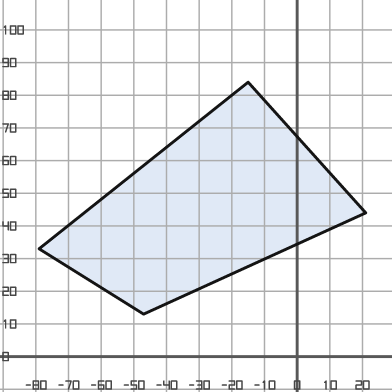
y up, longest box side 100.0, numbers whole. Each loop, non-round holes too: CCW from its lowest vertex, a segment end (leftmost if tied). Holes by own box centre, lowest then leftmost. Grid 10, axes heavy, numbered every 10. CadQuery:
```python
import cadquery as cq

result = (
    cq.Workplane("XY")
    .moveTo(-47.0, 13.0)
    .lineTo(21.0, 44.0)
    .lineTo(-15.0, 84.0)
    .lineTo(-79.0, 33.0)
    .close()
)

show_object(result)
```